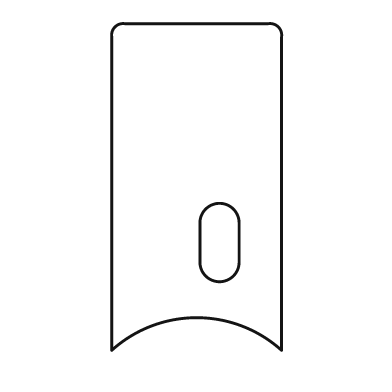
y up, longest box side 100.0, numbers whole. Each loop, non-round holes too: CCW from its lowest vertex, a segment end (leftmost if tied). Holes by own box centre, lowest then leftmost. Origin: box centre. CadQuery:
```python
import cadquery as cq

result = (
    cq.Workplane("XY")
    .moveTo(-26.0, -50.0)
    .threePointArc((0.0, -40.0), (26.0, -50.0))
    .lineTo(26.0, 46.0)
    .threePointArc((25.0, 49.0), (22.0, 50.0))
    .lineTo(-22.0, 50.0)
    .threePointArc((-25.0, 49.0), (-26.0, 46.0))
    .close()
    .moveTo(1.0, -23.0)
    .threePointArc((7.0, -29.0), (13.0, -23.0))
    .lineTo(13.0, -11.0)
    .threePointArc((7.0, -5.0), (1.0, -11.0))
    .close()
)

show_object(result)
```